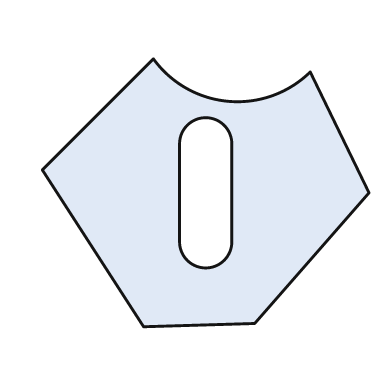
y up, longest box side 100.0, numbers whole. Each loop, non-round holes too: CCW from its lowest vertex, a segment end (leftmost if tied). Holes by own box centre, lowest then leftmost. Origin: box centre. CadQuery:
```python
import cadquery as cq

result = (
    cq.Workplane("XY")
    .moveTo(-19.0, -41.0)
    .lineTo(15.0, -40.0)
    .lineTo(50.0, 0.0)
    .lineTo(32.0, 37.0)
    .threePointArc((7.0, 28.0), (-16.0, 41.0))
    .lineTo(-50.0, 7.0)
    .close()
    .moveTo(-8.0, -15.0)
    .threePointArc((0.0, -23.0), (8.0, -15.0))
    .lineTo(8.0, 15.0)
    .threePointArc((0.0, 23.0), (-8.0, 15.0))
    .close()
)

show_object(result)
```